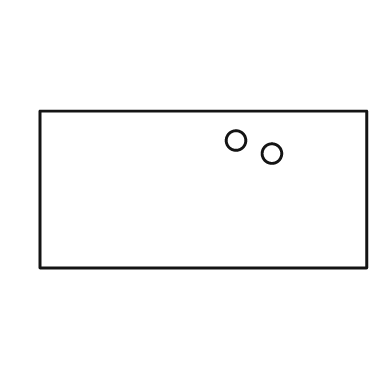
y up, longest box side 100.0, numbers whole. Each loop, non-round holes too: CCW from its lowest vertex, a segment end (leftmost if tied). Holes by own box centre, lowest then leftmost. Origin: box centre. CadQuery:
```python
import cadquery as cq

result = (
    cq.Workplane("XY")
    .moveTo(-50.0, -24.0)
    .lineTo(50.0, -24.0)
    .lineTo(50.0, 24.0)
    .lineTo(-50.0, 24.0)
    .close()
    .moveTo(21.0, 11.0)
    .circle(3.0)
    .moveTo(10.0, 15.0)
    .circle(3.0)
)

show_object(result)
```